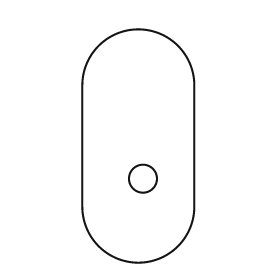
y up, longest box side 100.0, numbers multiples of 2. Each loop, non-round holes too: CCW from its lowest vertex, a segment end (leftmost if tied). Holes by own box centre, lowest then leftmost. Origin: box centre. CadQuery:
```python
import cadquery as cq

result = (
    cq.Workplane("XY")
    .moveTo(-24.0, -26.0)
    .threePointArc((0.0, -50.0), (24.0, -26.0))
    .lineTo(24.0, 26.0)
    .threePointArc((0.0, 50.0), (-24.0, 26.0))
    .close()
    .moveTo(2.0, -14.0)
    .circle(6.0)
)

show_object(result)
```